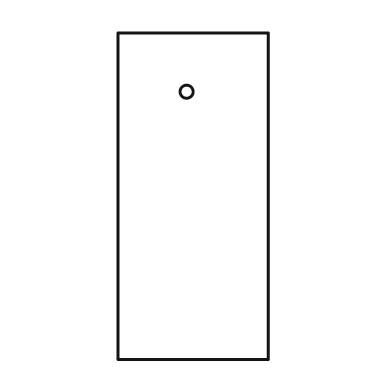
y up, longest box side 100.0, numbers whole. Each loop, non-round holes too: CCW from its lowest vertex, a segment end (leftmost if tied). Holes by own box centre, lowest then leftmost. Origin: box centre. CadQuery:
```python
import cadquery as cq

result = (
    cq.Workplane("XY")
    .moveTo(-23.0, -50.0)
    .lineTo(23.0, -50.0)
    .lineTo(23.0, 50.0)
    .lineTo(-23.0, 50.0)
    .close()
    .moveTo(-2.0, 32.0)
    .circle(2.0)
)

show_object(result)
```